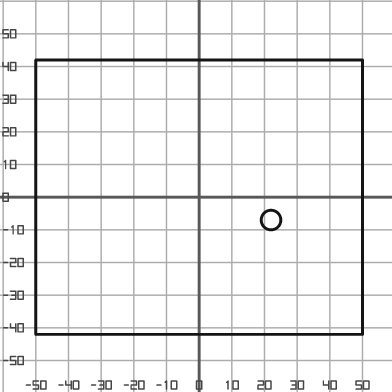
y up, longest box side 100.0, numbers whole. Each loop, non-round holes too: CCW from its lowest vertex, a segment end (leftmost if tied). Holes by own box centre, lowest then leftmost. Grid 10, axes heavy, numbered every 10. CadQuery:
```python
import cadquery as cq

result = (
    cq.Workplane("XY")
    .moveTo(-50.0, -42.0)
    .lineTo(50.0, -42.0)
    .lineTo(50.0, 42.0)
    .lineTo(-50.0, 42.0)
    .close()
    .moveTo(22.0, -7.0)
    .circle(3.0)
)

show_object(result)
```